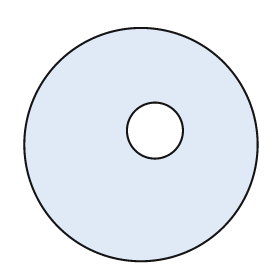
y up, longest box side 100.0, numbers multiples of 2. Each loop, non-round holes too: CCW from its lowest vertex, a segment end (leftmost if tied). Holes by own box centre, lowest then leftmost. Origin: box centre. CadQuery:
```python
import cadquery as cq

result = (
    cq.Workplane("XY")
    .moveTo(0.0, 0.0)
    .circle(50.0)
    .moveTo(6.0, 6.0)
    .circle(12.0)
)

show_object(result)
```